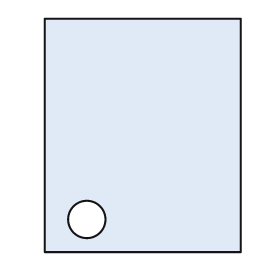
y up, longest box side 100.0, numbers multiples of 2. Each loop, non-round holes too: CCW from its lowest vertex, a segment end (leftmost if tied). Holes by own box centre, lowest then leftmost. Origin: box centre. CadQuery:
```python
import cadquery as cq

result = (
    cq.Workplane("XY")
    .moveTo(-42.0, -50.0)
    .lineTo(42.0, -50.0)
    .lineTo(42.0, 50.0)
    .lineTo(-42.0, 50.0)
    .close()
    .moveTo(-24.0, -36.0)
    .circle(8.0)
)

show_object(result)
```